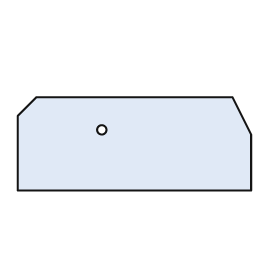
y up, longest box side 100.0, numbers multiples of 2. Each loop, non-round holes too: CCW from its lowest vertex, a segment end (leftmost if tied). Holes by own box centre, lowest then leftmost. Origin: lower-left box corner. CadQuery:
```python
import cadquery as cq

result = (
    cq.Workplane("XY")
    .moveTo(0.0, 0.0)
    .lineTo(100.0, 0.0)
    .lineTo(100.0, 24.0)
    .lineTo(92.0, 40.0)
    .lineTo(8.0, 40.0)
    .lineTo(0.0, 32.0)
    .close()
    .moveTo(36.0, 26.0)
    .circle(2.0)
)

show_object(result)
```